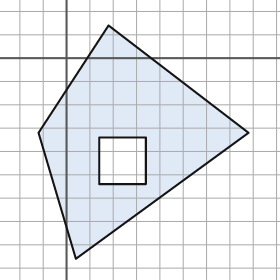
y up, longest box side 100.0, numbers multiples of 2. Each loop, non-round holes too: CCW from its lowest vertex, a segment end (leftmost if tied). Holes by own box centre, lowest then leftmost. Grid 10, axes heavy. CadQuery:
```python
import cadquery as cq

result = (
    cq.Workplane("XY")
    .moveTo(4.0, -86.0)
    .lineTo(78.0, -32.0)
    .lineTo(18.0, 14.0)
    .lineTo(-12.0, -32.0)
    .close()
    .moveTo(14.0, -54.0)
    .lineTo(34.0, -54.0)
    .lineTo(34.0, -34.0)
    .lineTo(14.0, -34.0)
    .close()
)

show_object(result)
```